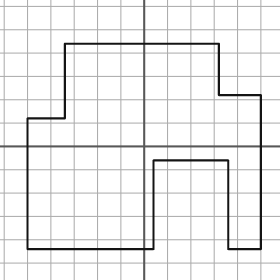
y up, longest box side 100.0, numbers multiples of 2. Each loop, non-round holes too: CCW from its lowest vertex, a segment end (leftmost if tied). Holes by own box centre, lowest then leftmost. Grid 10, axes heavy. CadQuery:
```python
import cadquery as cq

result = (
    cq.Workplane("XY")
    .moveTo(-50.0, -44.0)
    .lineTo(4.0, -44.0)
    .lineTo(4.0, -6.0)
    .lineTo(36.0, -6.0)
    .lineTo(36.0, -44.0)
    .lineTo(50.0, -44.0)
    .lineTo(50.0, 22.0)
    .lineTo(32.0, 22.0)
    .lineTo(32.0, 44.0)
    .lineTo(-34.0, 44.0)
    .lineTo(-34.0, 12.0)
    .lineTo(-50.0, 12.0)
    .close()
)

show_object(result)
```